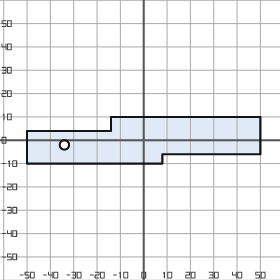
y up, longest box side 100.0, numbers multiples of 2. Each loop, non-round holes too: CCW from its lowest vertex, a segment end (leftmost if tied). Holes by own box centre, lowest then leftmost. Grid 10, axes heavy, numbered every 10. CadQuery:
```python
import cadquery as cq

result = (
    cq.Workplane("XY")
    .moveTo(-50.0, -10.0)
    .lineTo(8.0, -10.0)
    .lineTo(8.0, -6.0)
    .lineTo(50.0, -6.0)
    .lineTo(50.0, 10.0)
    .lineTo(-14.0, 10.0)
    .lineTo(-14.0, 4.0)
    .lineTo(-50.0, 4.0)
    .close()
    .moveTo(-34.0, -2.0)
    .circle(2.0)
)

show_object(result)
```